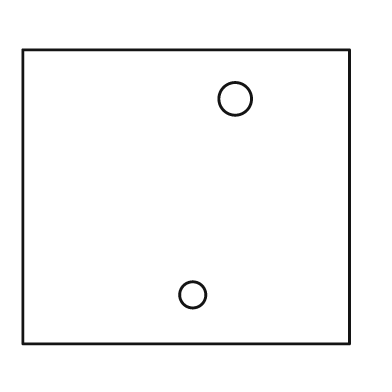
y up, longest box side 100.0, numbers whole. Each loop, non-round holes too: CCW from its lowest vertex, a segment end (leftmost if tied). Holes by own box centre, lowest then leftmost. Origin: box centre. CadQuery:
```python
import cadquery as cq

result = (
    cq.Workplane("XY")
    .moveTo(-50.0, -45.0)
    .lineTo(50.0, -45.0)
    .lineTo(50.0, 45.0)
    .lineTo(-50.0, 45.0)
    .close()
    .moveTo(2.0, -30.0)
    .circle(4.0)
    .moveTo(15.0, 30.0)
    .circle(5.0)
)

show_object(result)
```